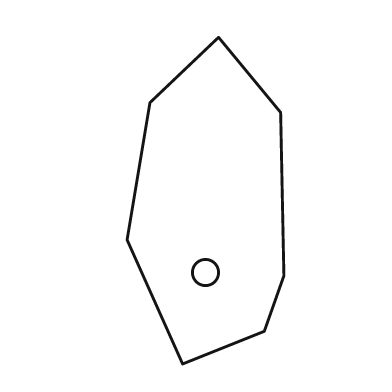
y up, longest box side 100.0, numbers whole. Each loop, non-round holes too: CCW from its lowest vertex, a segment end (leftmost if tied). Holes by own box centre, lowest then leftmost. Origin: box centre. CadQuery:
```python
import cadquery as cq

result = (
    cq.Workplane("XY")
    .moveTo(-7.0, -50.0)
    .lineTo(18.0, -40.0)
    .lineTo(24.0, -23.0)
    .lineTo(23.0, 27.0)
    .lineTo(4.0, 50.0)
    .lineTo(-17.0, 30.0)
    .lineTo(-24.0, -12.0)
    .close()
    .moveTo(0.0, -22.0)
    .circle(4.0)
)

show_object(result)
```